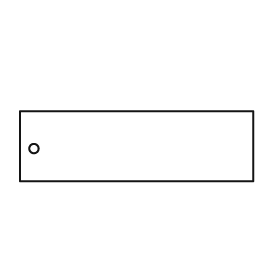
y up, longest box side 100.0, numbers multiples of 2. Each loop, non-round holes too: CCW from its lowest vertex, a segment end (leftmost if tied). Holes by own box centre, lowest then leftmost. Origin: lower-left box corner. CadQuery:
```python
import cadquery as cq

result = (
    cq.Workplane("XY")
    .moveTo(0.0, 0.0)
    .lineTo(100.0, 0.0)
    .lineTo(100.0, 30.0)
    .lineTo(0.0, 30.0)
    .close()
    .moveTo(6.0, 14.0)
    .circle(2.0)
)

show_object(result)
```